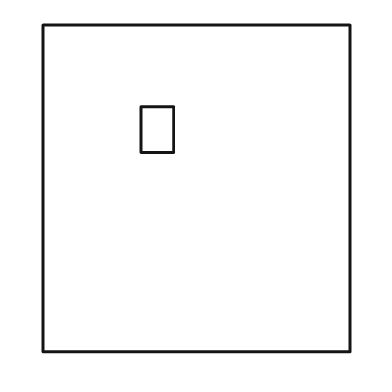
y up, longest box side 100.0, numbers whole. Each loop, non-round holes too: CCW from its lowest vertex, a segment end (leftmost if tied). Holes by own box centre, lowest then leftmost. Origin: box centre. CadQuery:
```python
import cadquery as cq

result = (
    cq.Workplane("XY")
    .moveTo(-47.0, -50.0)
    .lineTo(47.0, -50.0)
    .lineTo(47.0, 50.0)
    .lineTo(-47.0, 50.0)
    .close()
    .moveTo(-17.0, 11.0)
    .lineTo(-7.0, 11.0)
    .lineTo(-7.0, 25.0)
    .lineTo(-17.0, 25.0)
    .close()
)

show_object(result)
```